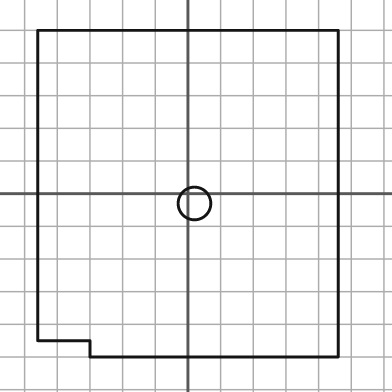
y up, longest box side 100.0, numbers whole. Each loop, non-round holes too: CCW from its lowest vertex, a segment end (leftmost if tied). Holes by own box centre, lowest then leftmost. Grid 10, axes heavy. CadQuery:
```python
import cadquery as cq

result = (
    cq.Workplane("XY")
    .moveTo(-30.0, -50.0)
    .lineTo(46.0, -50.0)
    .lineTo(46.0, 50.0)
    .lineTo(-46.0, 50.0)
    .lineTo(-46.0, -45.0)
    .lineTo(-30.0, -45.0)
    .close()
    .moveTo(2.0, -3.0)
    .circle(5.0)
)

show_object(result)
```